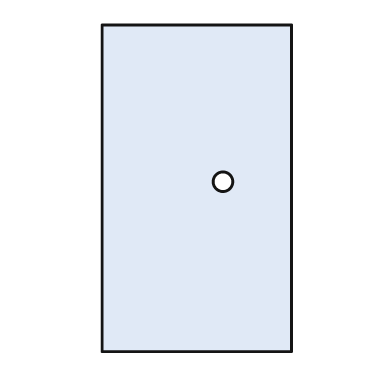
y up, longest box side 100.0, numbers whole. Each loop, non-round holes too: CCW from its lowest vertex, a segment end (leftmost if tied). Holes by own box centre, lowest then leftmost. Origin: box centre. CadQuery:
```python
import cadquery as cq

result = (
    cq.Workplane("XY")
    .moveTo(-29.0, -50.0)
    .lineTo(29.0, -50.0)
    .lineTo(29.0, 50.0)
    .lineTo(-29.0, 50.0)
    .close()
    .moveTo(8.0, 2.0)
    .circle(3.0)
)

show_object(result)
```